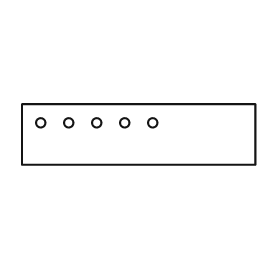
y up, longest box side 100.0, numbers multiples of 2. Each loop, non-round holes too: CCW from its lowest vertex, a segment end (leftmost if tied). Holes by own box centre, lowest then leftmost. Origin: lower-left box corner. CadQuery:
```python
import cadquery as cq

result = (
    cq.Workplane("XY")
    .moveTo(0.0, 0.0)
    .lineTo(100.0, 0.0)
    .lineTo(100.0, 26.0)
    .lineTo(0.0, 26.0)
    .close()
    .moveTo(8.0, 18.0)
    .circle(2.0)
    .moveTo(20.0, 18.0)
    .circle(2.0)
    .moveTo(32.0, 18.0)
    .circle(2.0)
    .moveTo(44.0, 18.0)
    .circle(2.0)
    .moveTo(56.0, 18.0)
    .circle(2.0)
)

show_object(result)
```